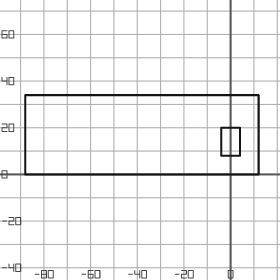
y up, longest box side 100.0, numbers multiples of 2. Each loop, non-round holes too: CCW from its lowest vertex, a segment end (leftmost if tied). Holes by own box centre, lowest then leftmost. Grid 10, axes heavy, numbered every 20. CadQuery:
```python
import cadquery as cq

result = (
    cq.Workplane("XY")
    .moveTo(-88.0, 0.0)
    .lineTo(12.0, 0.0)
    .lineTo(12.0, 34.0)
    .lineTo(-88.0, 34.0)
    .close()
    .moveTo(-4.0, 8.0)
    .lineTo(4.0, 8.0)
    .lineTo(4.0, 20.0)
    .lineTo(-4.0, 20.0)
    .close()
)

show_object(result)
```